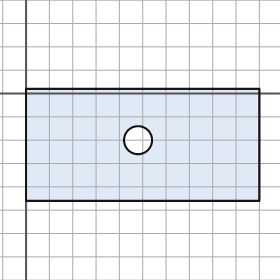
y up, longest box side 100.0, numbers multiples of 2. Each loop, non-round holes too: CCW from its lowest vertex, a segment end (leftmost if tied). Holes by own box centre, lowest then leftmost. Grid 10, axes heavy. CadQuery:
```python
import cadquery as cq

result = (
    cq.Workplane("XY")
    .moveTo(0.0, -46.0)
    .lineTo(100.0, -46.0)
    .lineTo(100.0, 2.0)
    .lineTo(0.0, 2.0)
    .close()
    .moveTo(48.0, -20.0)
    .circle(6.0)
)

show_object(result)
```